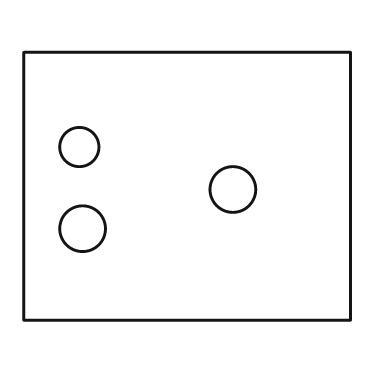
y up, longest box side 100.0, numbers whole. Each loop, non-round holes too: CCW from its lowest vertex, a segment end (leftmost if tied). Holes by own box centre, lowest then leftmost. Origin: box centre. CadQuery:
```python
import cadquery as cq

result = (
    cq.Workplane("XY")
    .moveTo(-50.0, -41.0)
    .lineTo(50.0, -41.0)
    .lineTo(50.0, 41.0)
    .lineTo(-50.0, 41.0)
    .close()
    .moveTo(-32.0, -13.0)
    .circle(7.0)
    .moveTo(14.0, -1.0)
    .circle(7.0)
    .moveTo(-33.0, 12.0)
    .circle(6.0)
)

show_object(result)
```